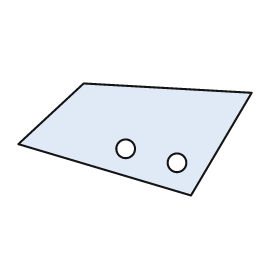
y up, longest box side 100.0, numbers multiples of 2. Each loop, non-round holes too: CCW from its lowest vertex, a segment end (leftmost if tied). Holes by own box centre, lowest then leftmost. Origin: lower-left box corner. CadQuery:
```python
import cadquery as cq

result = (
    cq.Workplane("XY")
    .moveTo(74.0, 0.0)
    .lineTo(100.0, 44.0)
    .lineTo(28.0, 48.0)
    .lineTo(0.0, 22.0)
    .close()
    .moveTo(68.0, 14.0)
    .circle(4.0)
    .moveTo(46.0, 20.0)
    .circle(4.0)
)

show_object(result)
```